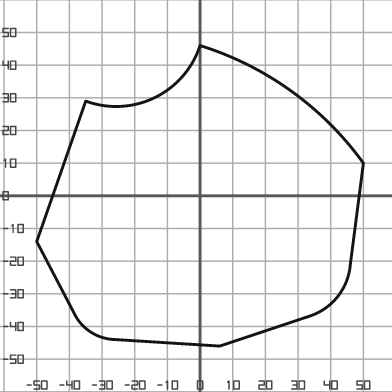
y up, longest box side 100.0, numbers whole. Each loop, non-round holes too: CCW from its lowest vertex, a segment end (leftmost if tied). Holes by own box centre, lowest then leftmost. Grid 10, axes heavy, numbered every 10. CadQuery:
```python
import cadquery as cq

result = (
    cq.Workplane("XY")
    .moveTo(6.0, -46.0)
    .lineTo(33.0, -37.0)
    .threePointArc((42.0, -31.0), (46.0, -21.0))
    .lineTo(50.0, 10.0)
    .threePointArc((28.0, 32.0), (0.0, 46.0))
    .threePointArc((-14.0, 30.0), (-35.0, 29.0))
    .lineTo(-50.0, -14.0)
    .lineTo(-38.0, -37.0)
    .threePointArc((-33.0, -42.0), (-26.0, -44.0))
    .close()
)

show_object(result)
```